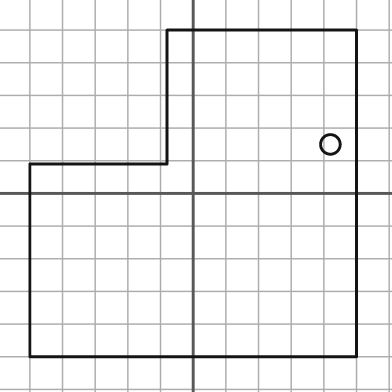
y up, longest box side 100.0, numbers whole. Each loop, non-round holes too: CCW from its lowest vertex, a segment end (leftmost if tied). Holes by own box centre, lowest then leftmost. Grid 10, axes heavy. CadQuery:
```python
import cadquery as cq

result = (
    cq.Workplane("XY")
    .moveTo(-50.0, -50.0)
    .lineTo(50.0, -50.0)
    .lineTo(50.0, 50.0)
    .lineTo(-8.0, 50.0)
    .lineTo(-8.0, 9.0)
    .lineTo(-50.0, 9.0)
    .close()
    .moveTo(42.0, 15.0)
    .circle(3.0)
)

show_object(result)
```